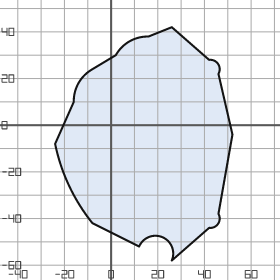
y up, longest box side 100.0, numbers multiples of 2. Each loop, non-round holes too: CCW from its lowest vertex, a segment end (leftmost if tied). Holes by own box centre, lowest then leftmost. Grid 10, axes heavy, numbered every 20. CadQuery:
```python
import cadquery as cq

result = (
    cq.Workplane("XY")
    .moveTo(26.0, -58.0)
    .lineTo(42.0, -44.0)
    .threePointArc((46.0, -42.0), (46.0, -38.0))
    .lineTo(52.0, -4.0)
    .lineTo(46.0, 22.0)
    .threePointArc((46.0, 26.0), (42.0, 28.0))
    .lineTo(26.0, 42.0)
    .lineTo(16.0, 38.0)
    .threePointArc((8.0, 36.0), (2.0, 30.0))
    .lineTo(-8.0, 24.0)
    .threePointArc((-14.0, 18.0), (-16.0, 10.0))
    .lineTo(-24.0, -8.0)
    .threePointArc((-18.0, -26.0), (-8.0, -42.0))
    .lineTo(12.0, -52.0)
    .threePointArc((22.0, -48.0), (26.0, -58.0))
    .close()
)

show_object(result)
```